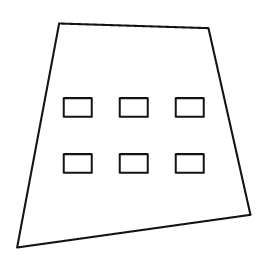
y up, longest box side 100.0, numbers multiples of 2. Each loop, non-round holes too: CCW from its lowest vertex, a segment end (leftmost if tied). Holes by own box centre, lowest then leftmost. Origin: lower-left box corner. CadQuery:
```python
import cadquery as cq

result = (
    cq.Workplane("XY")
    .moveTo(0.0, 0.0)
    .lineTo(100.0, 14.0)
    .lineTo(82.0, 94.0)
    .lineTo(18.0, 96.0)
    .close()
    .moveTo(20.0, 32.0)
    .lineTo(32.0, 32.0)
    .lineTo(32.0, 40.0)
    .lineTo(20.0, 40.0)
    .close()
    .moveTo(44.0, 32.0)
    .lineTo(56.0, 32.0)
    .lineTo(56.0, 40.0)
    .lineTo(44.0, 40.0)
    .close()
    .moveTo(68.0, 32.0)
    .lineTo(80.0, 32.0)
    .lineTo(80.0, 40.0)
    .lineTo(68.0, 40.0)
    .close()
    .moveTo(20.0, 56.0)
    .lineTo(32.0, 56.0)
    .lineTo(32.0, 64.0)
    .lineTo(20.0, 64.0)
    .close()
    .moveTo(44.0, 56.0)
    .lineTo(56.0, 56.0)
    .lineTo(56.0, 64.0)
    .lineTo(44.0, 64.0)
    .close()
    .moveTo(68.0, 56.0)
    .lineTo(80.0, 56.0)
    .lineTo(80.0, 64.0)
    .lineTo(68.0, 64.0)
    .close()
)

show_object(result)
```